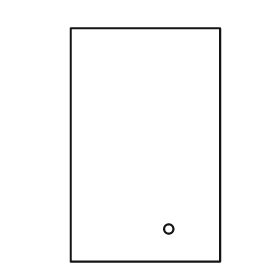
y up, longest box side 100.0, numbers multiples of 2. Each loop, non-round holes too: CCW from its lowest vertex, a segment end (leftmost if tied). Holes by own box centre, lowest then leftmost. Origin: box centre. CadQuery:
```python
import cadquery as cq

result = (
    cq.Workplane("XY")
    .moveTo(-32.0, -50.0)
    .lineTo(32.0, -50.0)
    .lineTo(32.0, 50.0)
    .lineTo(-32.0, 50.0)
    .close()
    .moveTo(10.0, -36.0)
    .circle(2.0)
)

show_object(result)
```